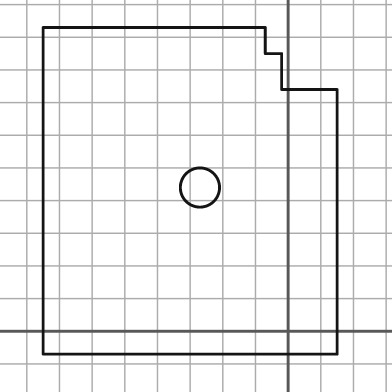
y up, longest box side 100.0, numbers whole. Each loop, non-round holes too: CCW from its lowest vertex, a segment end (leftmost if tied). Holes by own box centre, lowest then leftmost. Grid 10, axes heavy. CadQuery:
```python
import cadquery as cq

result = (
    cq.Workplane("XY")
    .moveTo(-75.0, -7.0)
    .lineTo(15.0, -7.0)
    .lineTo(15.0, 74.0)
    .lineTo(-2.0, 74.0)
    .lineTo(-2.0, 85.0)
    .lineTo(-7.0, 85.0)
    .lineTo(-7.0, 93.0)
    .lineTo(-75.0, 93.0)
    .close()
    .moveTo(-27.0, 44.0)
    .circle(6.0)
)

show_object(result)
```